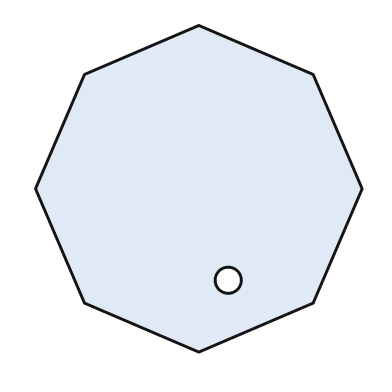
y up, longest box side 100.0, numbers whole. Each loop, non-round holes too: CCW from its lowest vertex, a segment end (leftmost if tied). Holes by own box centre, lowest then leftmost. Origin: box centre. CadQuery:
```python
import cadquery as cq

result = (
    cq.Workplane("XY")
    .moveTo(0.0, -50.0)
    .lineTo(35.0, -35.0)
    .lineTo(50.0, 0.0)
    .lineTo(35.0, 35.0)
    .lineTo(0.0, 50.0)
    .lineTo(-35.0, 35.0)
    .lineTo(-50.0, 0.0)
    .lineTo(-35.0, -35.0)
    .close()
    .moveTo(9.0, -28.0)
    .circle(4.0)
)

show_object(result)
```